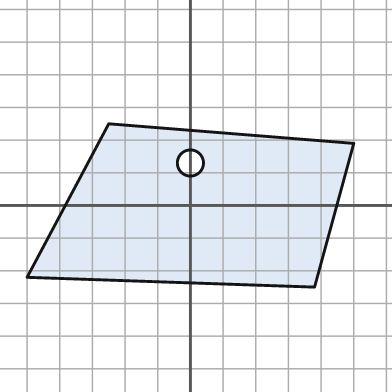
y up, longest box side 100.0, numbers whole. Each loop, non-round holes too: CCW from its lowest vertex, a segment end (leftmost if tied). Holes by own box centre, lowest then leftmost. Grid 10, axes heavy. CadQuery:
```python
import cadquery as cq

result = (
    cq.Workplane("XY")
    .moveTo(38.0, -25.0)
    .lineTo(50.0, 19.0)
    .lineTo(-25.0, 25.0)
    .lineTo(-50.0, -22.0)
    .close()
    .moveTo(0.0, 13.0)
    .circle(4.0)
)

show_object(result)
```